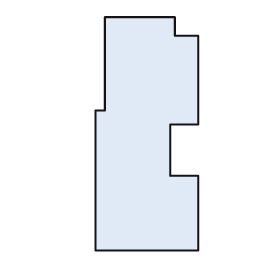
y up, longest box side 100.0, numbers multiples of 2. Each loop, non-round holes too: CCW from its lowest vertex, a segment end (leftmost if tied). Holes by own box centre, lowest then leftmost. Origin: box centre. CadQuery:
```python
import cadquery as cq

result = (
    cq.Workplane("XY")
    .moveTo(-22.0, -50.0)
    .lineTo(22.0, -50.0)
    .lineTo(22.0, -18.0)
    .lineTo(10.0, -18.0)
    .lineTo(10.0, 4.0)
    .lineTo(22.0, 4.0)
    .lineTo(22.0, 42.0)
    .lineTo(12.0, 42.0)
    .lineTo(12.0, 50.0)
    .lineTo(-18.0, 50.0)
    .lineTo(-18.0, 10.0)
    .lineTo(-22.0, 10.0)
    .close()
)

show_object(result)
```